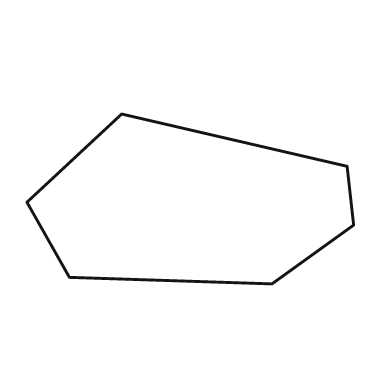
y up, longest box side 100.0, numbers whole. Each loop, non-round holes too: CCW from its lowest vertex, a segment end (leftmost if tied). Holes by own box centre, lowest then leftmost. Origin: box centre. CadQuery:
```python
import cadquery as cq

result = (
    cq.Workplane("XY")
    .moveTo(25.0, -26.0)
    .lineTo(50.0, -8.0)
    .lineTo(48.0, 10.0)
    .lineTo(-21.0, 26.0)
    .lineTo(-50.0, -1.0)
    .lineTo(-37.0, -24.0)
    .close()
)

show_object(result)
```